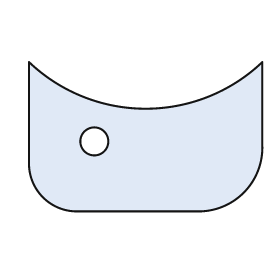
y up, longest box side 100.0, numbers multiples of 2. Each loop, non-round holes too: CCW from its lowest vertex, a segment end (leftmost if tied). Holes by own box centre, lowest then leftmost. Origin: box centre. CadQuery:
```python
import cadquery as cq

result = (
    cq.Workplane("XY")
    .moveTo(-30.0, -32.0)
    .lineTo(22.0, -32.0)
    .threePointArc((42.0, -24.0), (50.0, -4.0))
    .lineTo(50.0, 32.0)
    .threePointArc((0.0, 12.0), (-50.0, 32.0))
    .lineTo(-50.0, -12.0)
    .threePointArc((-44.0, -26.0), (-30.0, -32.0))
    .close()
    .moveTo(-22.0, -2.0)
    .circle(6.0)
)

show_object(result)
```